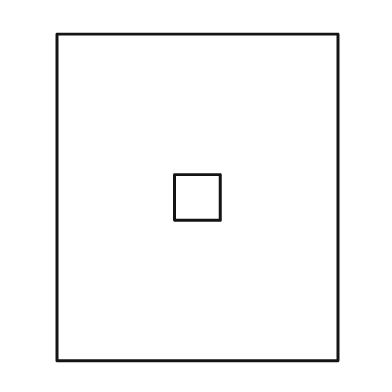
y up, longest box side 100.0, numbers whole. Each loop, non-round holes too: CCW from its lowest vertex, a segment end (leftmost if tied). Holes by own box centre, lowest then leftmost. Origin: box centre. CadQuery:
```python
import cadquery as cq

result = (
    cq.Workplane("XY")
    .moveTo(-43.0, -50.0)
    .lineTo(43.0, -50.0)
    .lineTo(43.0, 50.0)
    .lineTo(-43.0, 50.0)
    .close()
    .moveTo(-7.0, -7.0)
    .lineTo(7.0, -7.0)
    .lineTo(7.0, 7.0)
    .lineTo(-7.0, 7.0)
    .close()
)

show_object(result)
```